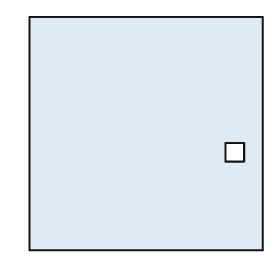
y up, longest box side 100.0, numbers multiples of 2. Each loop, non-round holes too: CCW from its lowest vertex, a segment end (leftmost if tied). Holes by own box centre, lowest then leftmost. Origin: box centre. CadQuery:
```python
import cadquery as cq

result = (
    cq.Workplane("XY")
    .moveTo(-50.0, -50.0)
    .lineTo(50.0, -50.0)
    .lineTo(50.0, 50.0)
    .lineTo(-50.0, 50.0)
    .close()
    .moveTo(34.0, -12.0)
    .lineTo(42.0, -12.0)
    .lineTo(42.0, -4.0)
    .lineTo(34.0, -4.0)
    .close()
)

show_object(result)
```